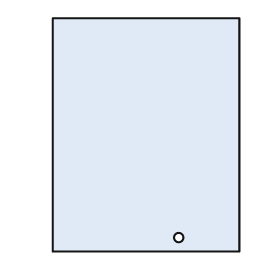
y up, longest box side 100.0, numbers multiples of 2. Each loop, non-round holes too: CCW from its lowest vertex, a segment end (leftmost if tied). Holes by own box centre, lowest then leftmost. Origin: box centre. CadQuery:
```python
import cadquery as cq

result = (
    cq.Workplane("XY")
    .moveTo(-40.0, -50.0)
    .lineTo(40.0, -50.0)
    .lineTo(40.0, 50.0)
    .lineTo(-40.0, 50.0)
    .close()
    .moveTo(14.0, -44.0)
    .circle(2.0)
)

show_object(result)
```